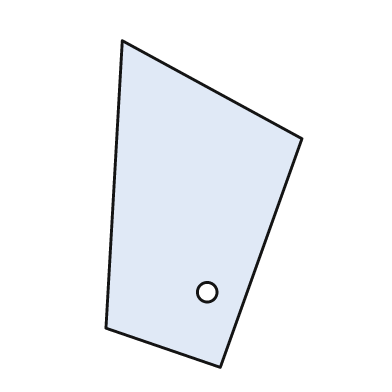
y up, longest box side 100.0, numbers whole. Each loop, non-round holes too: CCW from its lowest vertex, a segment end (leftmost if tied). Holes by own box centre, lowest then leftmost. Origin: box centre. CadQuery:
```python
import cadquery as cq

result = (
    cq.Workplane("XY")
    .moveTo(5.0, -50.0)
    .lineTo(30.0, 20.0)
    .lineTo(-25.0, 50.0)
    .lineTo(-30.0, -38.0)
    .close()
    .moveTo(1.0, -27.0)
    .circle(3.0)
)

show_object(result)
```